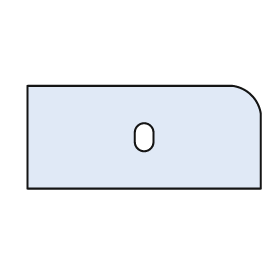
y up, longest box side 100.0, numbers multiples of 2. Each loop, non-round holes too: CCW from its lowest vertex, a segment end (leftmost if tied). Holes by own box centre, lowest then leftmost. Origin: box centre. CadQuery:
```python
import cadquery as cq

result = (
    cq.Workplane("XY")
    .moveTo(-50.0, -22.0)
    .lineTo(50.0, -22.0)
    .lineTo(50.0, 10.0)
    .threePointArc((46.0, 18.0), (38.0, 22.0))
    .lineTo(-50.0, 22.0)
    .close()
    .moveTo(-4.0, -2.0)
    .threePointArc((0.0, -6.0), (4.0, -2.0))
    .lineTo(4.0, 2.0)
    .threePointArc((0.0, 6.0), (-4.0, 2.0))
    .close()
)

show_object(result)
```